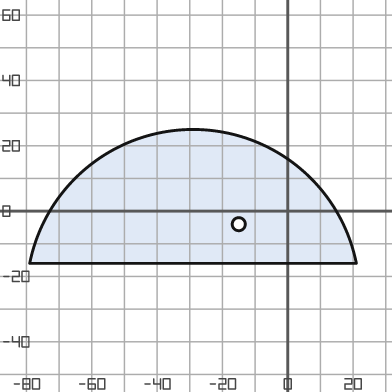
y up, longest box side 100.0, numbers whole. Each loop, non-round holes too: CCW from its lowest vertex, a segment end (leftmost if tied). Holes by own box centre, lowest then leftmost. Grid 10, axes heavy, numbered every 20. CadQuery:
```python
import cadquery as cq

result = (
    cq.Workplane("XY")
    .moveTo(-79.0, -16.0)
    .lineTo(21.0, -16.0)
    .threePointArc((-29.0, 25.0), (-79.0, -16.0))
    .close()
    .moveTo(-15.0, -4.0)
    .circle(2.0)
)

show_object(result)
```